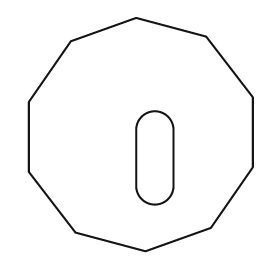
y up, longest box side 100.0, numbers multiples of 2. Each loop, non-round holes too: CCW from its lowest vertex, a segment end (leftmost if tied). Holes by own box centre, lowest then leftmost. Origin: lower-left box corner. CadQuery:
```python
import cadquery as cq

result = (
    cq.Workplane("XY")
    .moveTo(50.0, 0.0)
    .lineTo(78.0, 10.0)
    .lineTo(96.0, 36.0)
    .lineTo(96.0, 66.0)
    .lineTo(76.0, 92.0)
    .lineTo(46.0, 100.0)
    .lineTo(18.0, 90.0)
    .lineTo(0.0, 64.0)
    .lineTo(0.0, 34.0)
    .lineTo(20.0, 8.0)
    .close()
    .moveTo(46.0, 28.0)
    .threePointArc((54.0, 20.0), (62.0, 28.0))
    .lineTo(62.0, 52.0)
    .threePointArc((54.0, 60.0), (46.0, 52.0))
    .close()
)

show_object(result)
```